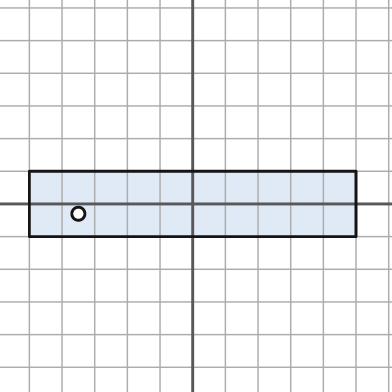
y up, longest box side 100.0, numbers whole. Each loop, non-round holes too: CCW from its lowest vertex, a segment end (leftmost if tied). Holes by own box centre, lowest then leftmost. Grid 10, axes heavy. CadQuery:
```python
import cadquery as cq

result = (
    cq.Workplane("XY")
    .moveTo(-50.0, -10.0)
    .lineTo(50.0, -10.0)
    .lineTo(50.0, 10.0)
    .lineTo(-50.0, 10.0)
    .close()
    .moveTo(-35.0, -3.0)
    .circle(2.0)
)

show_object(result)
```